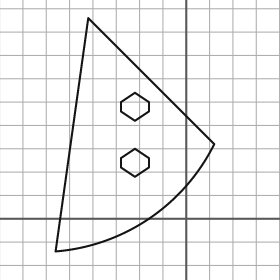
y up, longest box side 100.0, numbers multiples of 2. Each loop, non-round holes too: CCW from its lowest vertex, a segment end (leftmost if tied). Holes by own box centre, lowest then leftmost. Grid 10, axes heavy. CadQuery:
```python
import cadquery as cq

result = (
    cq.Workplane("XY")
    .moveTo(-56.0, -14.0)
    .threePointArc((-16.0, 0.0), (12.0, 32.0))
    .lineTo(-42.0, 86.0)
    .close()
    .moveTo(-22.0, 18.0)
    .lineTo(-16.0, 22.0)
    .lineTo(-16.0, 26.0)
    .lineTo(-22.0, 30.0)
    .lineTo(-28.0, 26.0)
    .lineTo(-28.0, 22.0)
    .close()
    .moveTo(-22.0, 42.0)
    .lineTo(-16.0, 46.0)
    .lineTo(-16.0, 50.0)
    .lineTo(-22.0, 54.0)
    .lineTo(-28.0, 50.0)
    .lineTo(-28.0, 46.0)
    .close()
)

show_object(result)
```